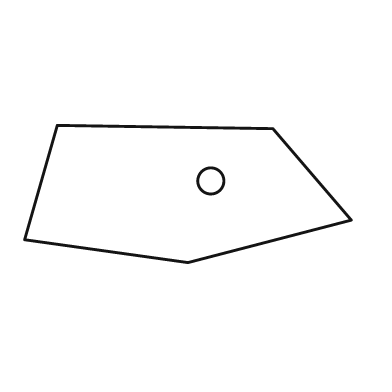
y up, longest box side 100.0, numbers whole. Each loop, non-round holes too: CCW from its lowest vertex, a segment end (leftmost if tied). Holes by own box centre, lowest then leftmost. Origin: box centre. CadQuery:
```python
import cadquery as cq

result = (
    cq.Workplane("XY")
    .moveTo(0.0, -21.0)
    .lineTo(50.0, -8.0)
    .lineTo(26.0, 20.0)
    .lineTo(-40.0, 21.0)
    .lineTo(-50.0, -14.0)
    .close()
    .moveTo(7.0, 4.0)
    .circle(4.0)
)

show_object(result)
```